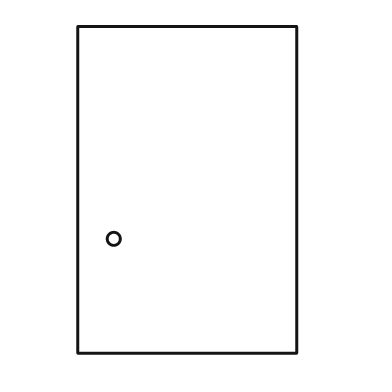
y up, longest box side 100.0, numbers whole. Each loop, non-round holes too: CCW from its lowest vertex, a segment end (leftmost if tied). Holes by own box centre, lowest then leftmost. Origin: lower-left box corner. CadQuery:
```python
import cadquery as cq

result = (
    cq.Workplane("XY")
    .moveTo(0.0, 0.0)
    .lineTo(67.0, 0.0)
    .lineTo(67.0, 100.0)
    .lineTo(0.0, 100.0)
    .close()
    .moveTo(11.0, 35.0)
    .circle(2.0)
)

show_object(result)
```